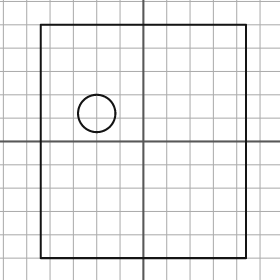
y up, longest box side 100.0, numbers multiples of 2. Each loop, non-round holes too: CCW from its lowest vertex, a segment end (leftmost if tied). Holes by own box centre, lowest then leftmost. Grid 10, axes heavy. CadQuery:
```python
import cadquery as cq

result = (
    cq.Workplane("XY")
    .moveTo(-44.0, -50.0)
    .lineTo(44.0, -50.0)
    .lineTo(44.0, 50.0)
    .lineTo(-44.0, 50.0)
    .close()
    .moveTo(-20.0, 12.0)
    .circle(8.0)
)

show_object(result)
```